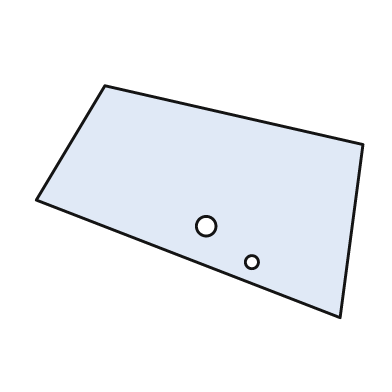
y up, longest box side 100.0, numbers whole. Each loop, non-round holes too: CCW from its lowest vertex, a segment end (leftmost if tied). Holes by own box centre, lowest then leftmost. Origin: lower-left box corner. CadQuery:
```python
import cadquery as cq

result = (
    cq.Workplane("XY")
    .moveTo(93.0, 0.0)
    .lineTo(100.0, 53.0)
    .lineTo(21.0, 71.0)
    .lineTo(0.0, 36.0)
    .close()
    .moveTo(66.0, 17.0)
    .circle(2.0)
    .moveTo(52.0, 28.0)
    .circle(3.0)
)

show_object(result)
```